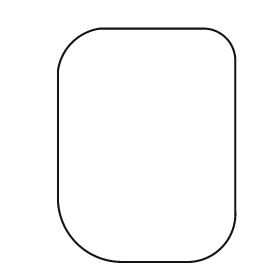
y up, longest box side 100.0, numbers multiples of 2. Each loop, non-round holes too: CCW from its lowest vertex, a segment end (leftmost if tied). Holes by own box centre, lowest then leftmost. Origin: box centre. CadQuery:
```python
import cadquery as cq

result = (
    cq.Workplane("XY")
    .moveTo(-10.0, -50.0)
    .lineTo(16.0, -50.0)
    .threePointArc((32.0, -44.0), (38.0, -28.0))
    .lineTo(38.0, 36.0)
    .threePointArc((34.0, 46.0), (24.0, 50.0))
    .lineTo(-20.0, 50.0)
    .threePointArc((-32.0, 44.0), (-38.0, 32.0))
    .lineTo(-38.0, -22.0)
    .threePointArc((-30.0, -42.0), (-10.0, -50.0))
    .close()
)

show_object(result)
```